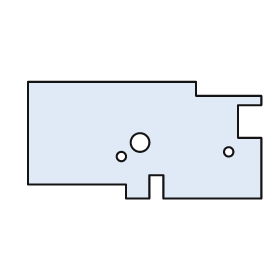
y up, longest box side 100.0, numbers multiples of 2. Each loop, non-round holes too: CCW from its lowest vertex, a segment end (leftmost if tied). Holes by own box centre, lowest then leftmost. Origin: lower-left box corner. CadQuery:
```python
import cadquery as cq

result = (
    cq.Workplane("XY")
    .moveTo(42.0, 0.0)
    .lineTo(52.0, 0.0)
    .lineTo(52.0, 10.0)
    .lineTo(58.0, 10.0)
    .lineTo(58.0, 0.0)
    .lineTo(100.0, 0.0)
    .lineTo(100.0, 26.0)
    .lineTo(90.0, 26.0)
    .lineTo(90.0, 40.0)
    .lineTo(100.0, 40.0)
    .lineTo(100.0, 44.0)
    .lineTo(72.0, 44.0)
    .lineTo(72.0, 50.0)
    .lineTo(0.0, 50.0)
    .lineTo(0.0, 6.0)
    .lineTo(42.0, 6.0)
    .close()
    .moveTo(40.0, 18.0)
    .circle(2.0)
    .moveTo(86.0, 20.0)
    .circle(2.0)
    .moveTo(48.0, 24.0)
    .circle(4.0)
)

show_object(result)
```